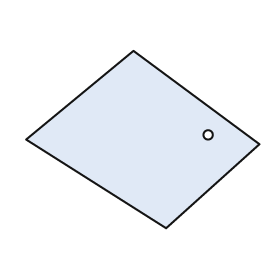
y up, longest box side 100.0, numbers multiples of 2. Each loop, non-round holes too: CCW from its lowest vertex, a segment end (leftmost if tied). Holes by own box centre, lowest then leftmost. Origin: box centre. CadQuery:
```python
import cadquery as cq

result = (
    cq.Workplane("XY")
    .moveTo(10.0, -38.0)
    .lineTo(50.0, -2.0)
    .lineTo(-4.0, 38.0)
    .lineTo(-50.0, 0.0)
    .close()
    .moveTo(28.0, 2.0)
    .circle(2.0)
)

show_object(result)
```